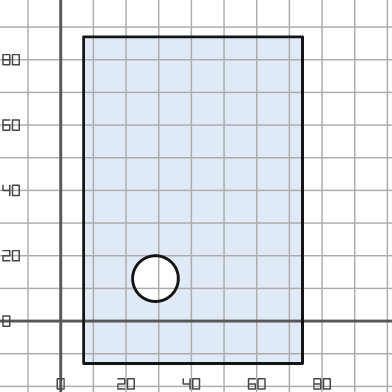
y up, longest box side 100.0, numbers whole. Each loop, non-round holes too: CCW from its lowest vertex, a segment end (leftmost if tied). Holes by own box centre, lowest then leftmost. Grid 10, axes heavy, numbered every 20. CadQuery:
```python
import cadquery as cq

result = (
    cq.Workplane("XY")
    .moveTo(7.0, -13.0)
    .lineTo(74.0, -13.0)
    .lineTo(74.0, 87.0)
    .lineTo(7.0, 87.0)
    .close()
    .moveTo(29.0, 13.0)
    .circle(7.0)
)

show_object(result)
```